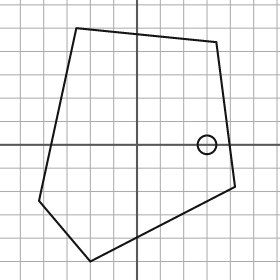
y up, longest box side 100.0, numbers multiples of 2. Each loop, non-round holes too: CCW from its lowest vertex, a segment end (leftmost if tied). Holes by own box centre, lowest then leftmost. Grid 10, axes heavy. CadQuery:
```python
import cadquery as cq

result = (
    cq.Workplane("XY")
    .moveTo(-20.0, -50.0)
    .lineTo(42.0, -18.0)
    .lineTo(34.0, 44.0)
    .lineTo(-26.0, 50.0)
    .lineTo(-42.0, -24.0)
    .close()
    .moveTo(30.0, 0.0)
    .circle(4.0)
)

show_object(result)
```